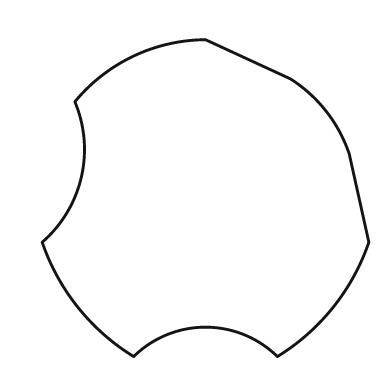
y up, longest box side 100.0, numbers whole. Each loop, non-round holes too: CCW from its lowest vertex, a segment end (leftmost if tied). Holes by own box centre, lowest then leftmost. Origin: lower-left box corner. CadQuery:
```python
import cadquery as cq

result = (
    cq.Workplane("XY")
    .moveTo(28.0, 0.0)
    .threePointArc((50.0, 9.0), (72.0, 0.0))
    .threePointArc((89.0, 15.0), (100.0, 35.0))
    .lineTo(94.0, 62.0)
    .threePointArc((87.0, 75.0), (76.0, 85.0))
    .lineTo(50.0, 97.0)
    .threePointArc((28.0, 92.0), (10.0, 78.0))
    .threePointArc((12.0, 55.0), (0.0, 35.0))
    .threePointArc((11.0, 15.0), (28.0, 0.0))
    .close()
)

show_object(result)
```